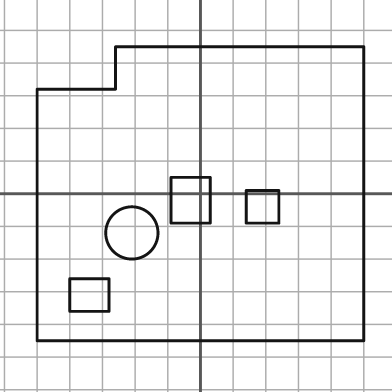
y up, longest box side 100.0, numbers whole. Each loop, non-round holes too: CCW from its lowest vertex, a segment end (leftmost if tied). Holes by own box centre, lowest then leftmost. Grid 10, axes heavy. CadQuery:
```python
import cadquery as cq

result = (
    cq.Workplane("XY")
    .moveTo(-50.0, -45.0)
    .lineTo(50.0, -45.0)
    .lineTo(50.0, 45.0)
    .lineTo(-26.0, 45.0)
    .lineTo(-26.0, 32.0)
    .lineTo(-50.0, 32.0)
    .close()
    .moveTo(-40.0, -36.0)
    .lineTo(-28.0, -36.0)
    .lineTo(-28.0, -26.0)
    .lineTo(-40.0, -26.0)
    .close()
    .moveTo(-21.0, -12.0)
    .circle(8.0)
    .moveTo(14.0, -9.0)
    .lineTo(24.0, -9.0)
    .lineTo(24.0, 1.0)
    .lineTo(14.0, 1.0)
    .close()
    .moveTo(-9.0, -9.0)
    .lineTo(3.0, -9.0)
    .lineTo(3.0, 5.0)
    .lineTo(-9.0, 5.0)
    .close()
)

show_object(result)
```